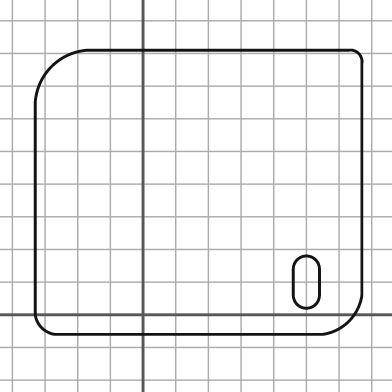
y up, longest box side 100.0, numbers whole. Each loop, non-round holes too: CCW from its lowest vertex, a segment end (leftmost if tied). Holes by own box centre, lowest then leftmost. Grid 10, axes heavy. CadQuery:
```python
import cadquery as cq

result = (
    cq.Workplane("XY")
    .moveTo(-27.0, -6.0)
    .lineTo(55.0, -6.0)
    .threePointArc((63.0, -2.0), (67.0, 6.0))
    .lineTo(67.0, 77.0)
    .threePointArc((66.0, 80.0), (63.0, 81.0))
    .lineTo(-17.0, 81.0)
    .threePointArc((-28.0, 76.0), (-33.0, 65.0))
    .lineTo(-33.0, 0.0)
    .threePointArc((-31.0, -4.0), (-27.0, -6.0))
    .close()
    .moveTo(46.0, 6.0)
    .threePointArc((50.0, 2.0), (54.0, 6.0))
    .lineTo(54.0, 14.0)
    .threePointArc((50.0, 18.0), (46.0, 14.0))
    .close()
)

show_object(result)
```